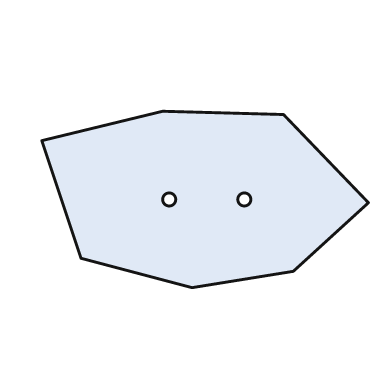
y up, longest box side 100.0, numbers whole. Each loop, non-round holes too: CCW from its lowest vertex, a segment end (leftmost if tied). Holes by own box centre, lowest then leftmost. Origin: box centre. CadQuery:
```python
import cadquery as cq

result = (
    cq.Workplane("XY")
    .moveTo(-4.0, -27.0)
    .lineTo(27.0, -22.0)
    .lineTo(50.0, -1.0)
    .lineTo(24.0, 26.0)
    .lineTo(-13.0, 27.0)
    .lineTo(-50.0, 18.0)
    .lineTo(-38.0, -18.0)
    .close()
    .moveTo(-11.0, 0.0)
    .circle(2.0)
    .moveTo(12.0, 0.0)
    .circle(2.0)
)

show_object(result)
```